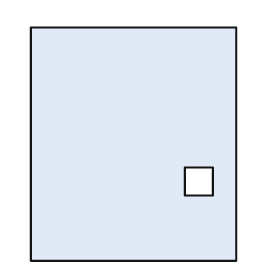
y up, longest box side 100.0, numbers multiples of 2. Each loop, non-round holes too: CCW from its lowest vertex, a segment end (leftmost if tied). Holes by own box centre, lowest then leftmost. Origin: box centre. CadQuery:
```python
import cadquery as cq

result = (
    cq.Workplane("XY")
    .moveTo(-44.0, -50.0)
    .lineTo(44.0, -50.0)
    .lineTo(44.0, 50.0)
    .lineTo(-44.0, 50.0)
    .close()
    .moveTo(22.0, -22.0)
    .lineTo(34.0, -22.0)
    .lineTo(34.0, -10.0)
    .lineTo(22.0, -10.0)
    .close()
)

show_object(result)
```